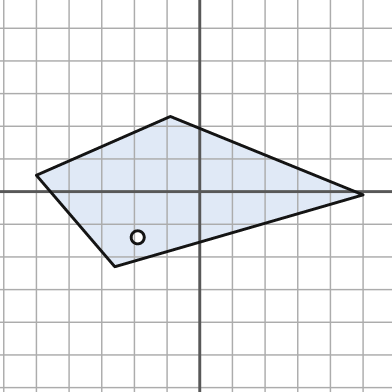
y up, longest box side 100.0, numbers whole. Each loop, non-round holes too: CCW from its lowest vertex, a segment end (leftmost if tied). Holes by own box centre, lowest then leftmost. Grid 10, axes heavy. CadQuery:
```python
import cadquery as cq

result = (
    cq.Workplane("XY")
    .moveTo(-26.0, -23.0)
    .lineTo(50.0, -1.0)
    .lineTo(-9.0, 23.0)
    .lineTo(-50.0, 5.0)
    .close()
    .moveTo(-19.0, -14.0)
    .circle(2.0)
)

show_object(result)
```